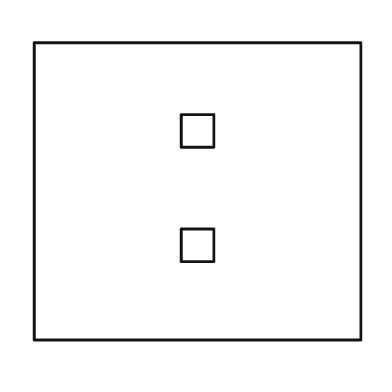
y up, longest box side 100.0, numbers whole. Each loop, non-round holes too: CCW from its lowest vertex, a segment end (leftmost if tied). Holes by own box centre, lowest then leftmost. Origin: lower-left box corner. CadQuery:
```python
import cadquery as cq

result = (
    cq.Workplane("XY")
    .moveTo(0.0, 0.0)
    .lineTo(100.0, 0.0)
    .lineTo(100.0, 91.0)
    .lineTo(0.0, 91.0)
    .close()
    .moveTo(45.0, 24.0)
    .lineTo(55.0, 24.0)
    .lineTo(55.0, 34.0)
    .lineTo(45.0, 34.0)
    .close()
    .moveTo(45.0, 59.0)
    .lineTo(55.0, 59.0)
    .lineTo(55.0, 69.0)
    .lineTo(45.0, 69.0)
    .close()
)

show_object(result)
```